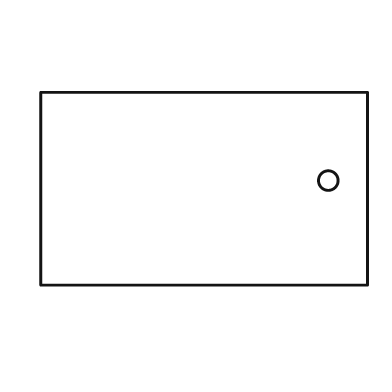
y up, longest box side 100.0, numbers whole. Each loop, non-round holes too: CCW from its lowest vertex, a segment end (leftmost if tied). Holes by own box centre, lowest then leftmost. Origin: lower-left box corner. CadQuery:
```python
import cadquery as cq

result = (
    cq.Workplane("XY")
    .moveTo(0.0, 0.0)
    .lineTo(100.0, 0.0)
    .lineTo(100.0, 59.0)
    .lineTo(0.0, 59.0)
    .close()
    .moveTo(88.0, 32.0)
    .circle(3.0)
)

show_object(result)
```